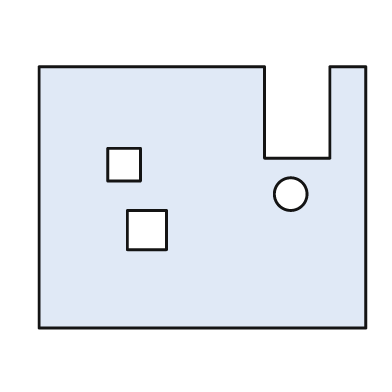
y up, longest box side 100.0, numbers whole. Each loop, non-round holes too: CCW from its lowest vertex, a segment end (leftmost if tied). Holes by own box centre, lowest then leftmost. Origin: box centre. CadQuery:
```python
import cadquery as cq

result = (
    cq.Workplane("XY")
    .moveTo(-50.0, -40.0)
    .lineTo(50.0, -40.0)
    .lineTo(50.0, 40.0)
    .lineTo(39.0, 40.0)
    .lineTo(39.0, 12.0)
    .lineTo(19.0, 12.0)
    .lineTo(19.0, 40.0)
    .lineTo(-50.0, 40.0)
    .close()
    .moveTo(-23.0, -16.0)
    .lineTo(-11.0, -16.0)
    .lineTo(-11.0, -4.0)
    .lineTo(-23.0, -4.0)
    .close()
    .moveTo(27.0, 1.0)
    .circle(5.0)
    .moveTo(-29.0, 5.0)
    .lineTo(-19.0, 5.0)
    .lineTo(-19.0, 15.0)
    .lineTo(-29.0, 15.0)
    .close()
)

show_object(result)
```